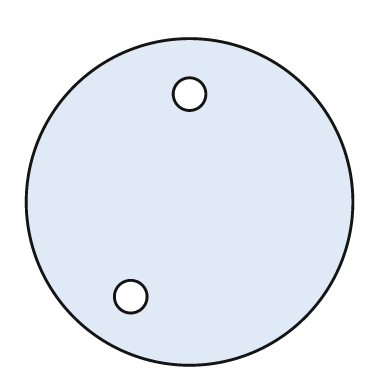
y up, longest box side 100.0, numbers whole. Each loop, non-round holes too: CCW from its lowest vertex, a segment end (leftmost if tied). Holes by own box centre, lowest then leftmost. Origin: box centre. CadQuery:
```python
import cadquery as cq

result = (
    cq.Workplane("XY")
    .moveTo(0.0, 0.0)
    .circle(50.0)
    .moveTo(-18.0, -29.0)
    .circle(5.0)
    .moveTo(0.0, 33.0)
    .circle(5.0)
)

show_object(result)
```